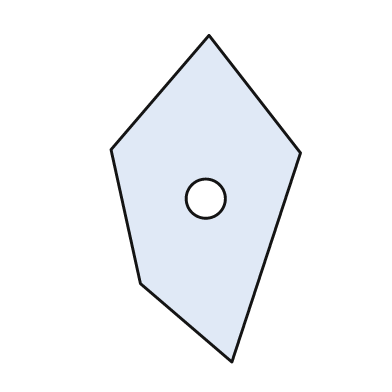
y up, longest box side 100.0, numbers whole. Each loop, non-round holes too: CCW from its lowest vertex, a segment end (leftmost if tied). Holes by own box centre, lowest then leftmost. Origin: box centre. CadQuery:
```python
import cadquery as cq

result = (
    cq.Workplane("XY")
    .moveTo(8.0, -50.0)
    .lineTo(29.0, 14.0)
    .lineTo(1.0, 50.0)
    .lineTo(-29.0, 15.0)
    .lineTo(-20.0, -26.0)
    .close()
    .moveTo(0.0, 0.0)
    .circle(6.0)
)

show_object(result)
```